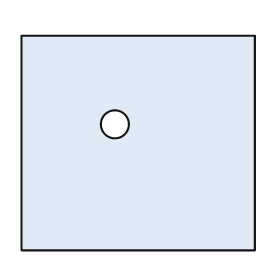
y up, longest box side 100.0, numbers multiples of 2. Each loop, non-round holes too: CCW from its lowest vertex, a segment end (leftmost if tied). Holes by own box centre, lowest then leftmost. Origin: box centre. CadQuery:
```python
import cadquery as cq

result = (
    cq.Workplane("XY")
    .moveTo(-50.0, -46.0)
    .lineTo(50.0, -46.0)
    .lineTo(50.0, 46.0)
    .lineTo(-50.0, 46.0)
    .close()
    .moveTo(-10.0, 8.0)
    .circle(6.0)
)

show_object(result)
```